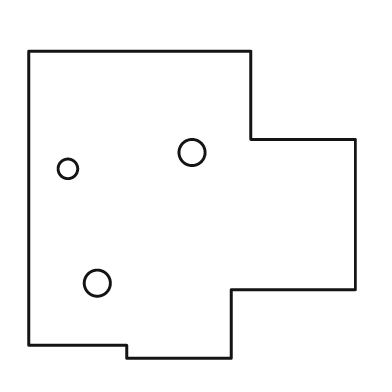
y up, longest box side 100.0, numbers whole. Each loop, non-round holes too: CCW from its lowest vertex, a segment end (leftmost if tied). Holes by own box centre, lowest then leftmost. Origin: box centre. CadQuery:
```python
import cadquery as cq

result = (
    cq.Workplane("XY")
    .moveTo(-20.0, -47.0)
    .lineTo(12.0, -47.0)
    .lineTo(12.0, -26.0)
    .lineTo(50.0, -26.0)
    .lineTo(50.0, 20.0)
    .lineTo(18.0, 20.0)
    .lineTo(18.0, 47.0)
    .lineTo(-50.0, 47.0)
    .lineTo(-50.0, -43.0)
    .lineTo(-20.0, -43.0)
    .close()
    .moveTo(-29.0, -24.0)
    .circle(4.0)
    .moveTo(-38.0, 11.0)
    .circle(3.0)
    .moveTo(0.0, 16.0)
    .circle(4.0)
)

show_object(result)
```